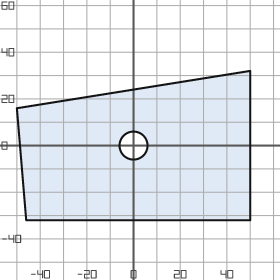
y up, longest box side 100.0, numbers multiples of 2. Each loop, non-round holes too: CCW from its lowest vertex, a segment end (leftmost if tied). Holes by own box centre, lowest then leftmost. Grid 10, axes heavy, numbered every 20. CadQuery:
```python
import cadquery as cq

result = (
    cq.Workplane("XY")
    .moveTo(-46.0, -32.0)
    .lineTo(50.0, -32.0)
    .lineTo(50.0, 32.0)
    .lineTo(-50.0, 16.0)
    .close()
    .moveTo(0.0, 0.0)
    .circle(6.0)
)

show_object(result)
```